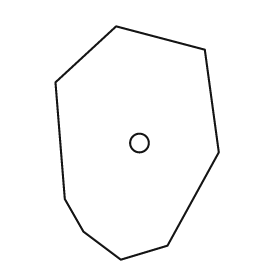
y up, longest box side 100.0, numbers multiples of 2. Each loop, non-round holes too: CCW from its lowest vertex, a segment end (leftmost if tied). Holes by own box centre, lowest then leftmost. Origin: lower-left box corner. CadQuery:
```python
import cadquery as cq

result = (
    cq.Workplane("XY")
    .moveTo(28.0, 0.0)
    .lineTo(48.0, 6.0)
    .lineTo(70.0, 46.0)
    .lineTo(64.0, 90.0)
    .lineTo(26.0, 100.0)
    .lineTo(0.0, 76.0)
    .lineTo(4.0, 26.0)
    .lineTo(12.0, 12.0)
    .close()
    .moveTo(36.0, 50.0)
    .circle(4.0)
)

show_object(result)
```